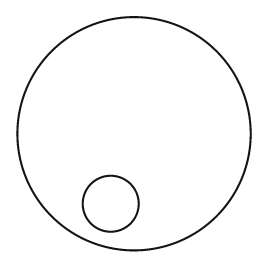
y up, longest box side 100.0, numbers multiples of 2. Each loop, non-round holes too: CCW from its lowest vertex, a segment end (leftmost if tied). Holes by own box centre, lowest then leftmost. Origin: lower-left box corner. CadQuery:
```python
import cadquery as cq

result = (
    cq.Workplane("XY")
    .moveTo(50.0, 50.0)
    .circle(50.0)
    .moveTo(40.0, 20.0)
    .circle(12.0)
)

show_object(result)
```